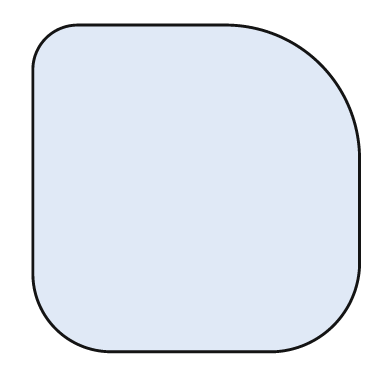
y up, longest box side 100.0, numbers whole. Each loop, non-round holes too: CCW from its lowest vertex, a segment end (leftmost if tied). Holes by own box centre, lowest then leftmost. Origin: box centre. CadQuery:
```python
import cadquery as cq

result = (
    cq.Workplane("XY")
    .moveTo(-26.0, -50.0)
    .lineTo(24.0, -50.0)
    .threePointArc((42.0, -42.0), (50.0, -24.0))
    .lineTo(50.0, 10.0)
    .threePointArc((38.0, 38.0), (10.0, 50.0))
    .lineTo(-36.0, 50.0)
    .threePointArc((-46.0, 46.0), (-50.0, 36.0))
    .lineTo(-50.0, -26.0)
    .threePointArc((-43.0, -43.0), (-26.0, -50.0))
    .close()
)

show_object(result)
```